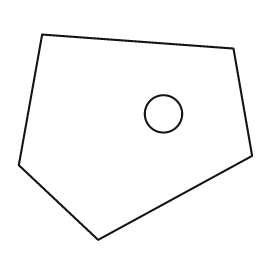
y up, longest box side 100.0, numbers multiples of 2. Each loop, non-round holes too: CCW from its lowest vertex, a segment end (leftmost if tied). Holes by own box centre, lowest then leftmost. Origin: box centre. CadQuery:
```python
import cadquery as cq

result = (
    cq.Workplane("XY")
    .moveTo(-16.0, -44.0)
    .lineTo(50.0, -8.0)
    .lineTo(42.0, 38.0)
    .lineTo(-40.0, 44.0)
    .lineTo(-50.0, -12.0)
    .close()
    .moveTo(12.0, 10.0)
    .circle(8.0)
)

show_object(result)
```